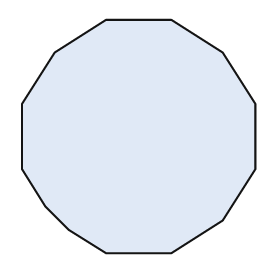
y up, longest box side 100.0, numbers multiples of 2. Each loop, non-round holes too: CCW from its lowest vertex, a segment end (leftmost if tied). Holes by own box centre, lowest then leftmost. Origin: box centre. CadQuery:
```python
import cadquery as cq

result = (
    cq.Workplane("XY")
    .moveTo(-14.0, -50.0)
    .lineTo(14.0, -50.0)
    .lineTo(36.0, -36.0)
    .lineTo(50.0, -14.0)
    .lineTo(50.0, 14.0)
    .lineTo(36.0, 36.0)
    .lineTo(14.0, 50.0)
    .lineTo(-14.0, 50.0)
    .lineTo(-36.0, 36.0)
    .lineTo(-50.0, 14.0)
    .lineTo(-50.0, -14.0)
    .lineTo(-40.0, -30.0)
    .lineTo(-30.0, -40.0)
    .close()
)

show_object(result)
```